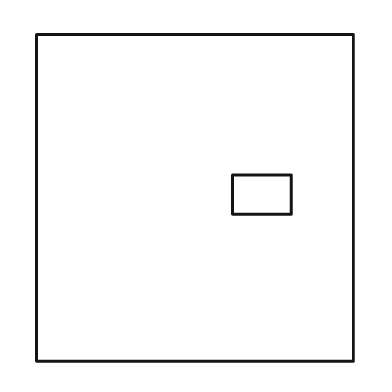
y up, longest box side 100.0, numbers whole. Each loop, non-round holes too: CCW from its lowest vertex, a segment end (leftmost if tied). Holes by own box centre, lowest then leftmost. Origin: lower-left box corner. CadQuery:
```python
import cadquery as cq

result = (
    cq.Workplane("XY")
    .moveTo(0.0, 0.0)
    .lineTo(97.0, 0.0)
    .lineTo(97.0, 100.0)
    .lineTo(0.0, 100.0)
    .close()
    .moveTo(60.0, 45.0)
    .lineTo(78.0, 45.0)
    .lineTo(78.0, 57.0)
    .lineTo(60.0, 57.0)
    .close()
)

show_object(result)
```